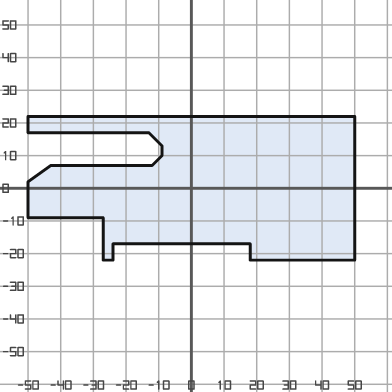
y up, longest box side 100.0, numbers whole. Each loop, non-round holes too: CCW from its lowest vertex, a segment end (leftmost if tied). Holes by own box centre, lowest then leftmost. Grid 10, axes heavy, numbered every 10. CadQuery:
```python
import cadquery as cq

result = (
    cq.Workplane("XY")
    .moveTo(-27.0, -22.0)
    .lineTo(-24.0, -22.0)
    .lineTo(-24.0, -17.0)
    .lineTo(18.0, -17.0)
    .lineTo(18.0, -22.0)
    .lineTo(50.0, -22.0)
    .lineTo(50.0, 22.0)
    .lineTo(-50.0, 22.0)
    .lineTo(-50.0, 17.0)
    .lineTo(-13.0, 17.0)
    .lineTo(-9.0, 13.0)
    .lineTo(-9.0, 10.0)
    .lineTo(-12.0, 7.0)
    .lineTo(-43.0, 7.0)
    .lineTo(-50.0, 2.0)
    .lineTo(-50.0, -9.0)
    .lineTo(-27.0, -9.0)
    .close()
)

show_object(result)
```